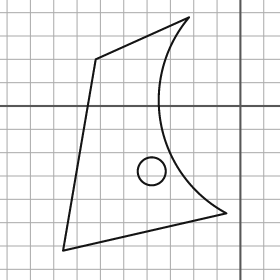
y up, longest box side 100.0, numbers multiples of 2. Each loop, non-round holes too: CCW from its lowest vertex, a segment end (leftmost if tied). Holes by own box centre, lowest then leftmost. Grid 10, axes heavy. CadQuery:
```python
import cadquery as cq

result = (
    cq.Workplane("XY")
    .moveTo(-76.0, -62.0)
    .lineTo(-6.0, -46.0)
    .threePointArc((-34.0, -8.0), (-22.0, 38.0))
    .lineTo(-62.0, 20.0)
    .close()
    .moveTo(-38.0, -28.0)
    .circle(6.0)
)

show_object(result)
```